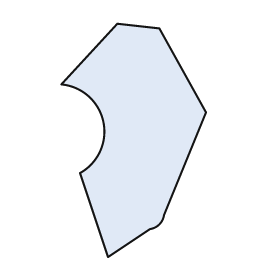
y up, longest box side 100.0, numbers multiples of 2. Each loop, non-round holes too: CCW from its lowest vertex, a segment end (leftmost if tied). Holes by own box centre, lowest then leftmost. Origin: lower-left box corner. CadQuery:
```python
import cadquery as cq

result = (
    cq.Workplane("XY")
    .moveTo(20.0, 0.0)
    .lineTo(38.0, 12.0)
    .threePointArc((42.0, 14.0), (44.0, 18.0))
    .lineTo(62.0, 62.0)
    .lineTo(42.0, 98.0)
    .lineTo(24.0, 100.0)
    .lineTo(0.0, 74.0)
    .threePointArc((18.0, 58.0), (8.0, 36.0))
    .close()
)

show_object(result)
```